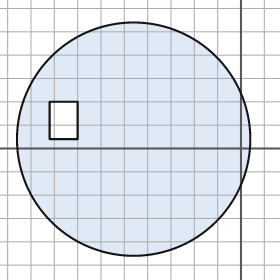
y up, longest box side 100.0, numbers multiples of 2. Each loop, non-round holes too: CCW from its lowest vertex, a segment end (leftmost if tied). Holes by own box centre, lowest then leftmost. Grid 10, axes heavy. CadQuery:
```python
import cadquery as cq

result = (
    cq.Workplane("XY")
    .moveTo(-46.0, 4.0)
    .circle(50.0)
    .moveTo(-82.0, 4.0)
    .lineTo(-70.0, 4.0)
    .lineTo(-70.0, 20.0)
    .lineTo(-82.0, 20.0)
    .close()
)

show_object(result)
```